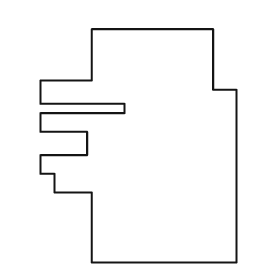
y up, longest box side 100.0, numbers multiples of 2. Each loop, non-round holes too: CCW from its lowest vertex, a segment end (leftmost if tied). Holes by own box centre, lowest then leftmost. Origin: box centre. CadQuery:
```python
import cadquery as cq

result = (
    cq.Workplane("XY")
    .moveTo(-20.0, -50.0)
    .lineTo(42.0, -50.0)
    .lineTo(42.0, 24.0)
    .lineTo(32.0, 24.0)
    .lineTo(32.0, 50.0)
    .lineTo(-20.0, 50.0)
    .lineTo(-20.0, 28.0)
    .lineTo(-42.0, 28.0)
    .lineTo(-42.0, 18.0)
    .lineTo(-6.0, 18.0)
    .lineTo(-6.0, 14.0)
    .lineTo(-42.0, 14.0)
    .lineTo(-42.0, 6.0)
    .lineTo(-22.0, 6.0)
    .lineTo(-22.0, -4.0)
    .lineTo(-42.0, -4.0)
    .lineTo(-42.0, -12.0)
    .lineTo(-36.0, -12.0)
    .lineTo(-36.0, -20.0)
    .lineTo(-20.0, -20.0)
    .close()
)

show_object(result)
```